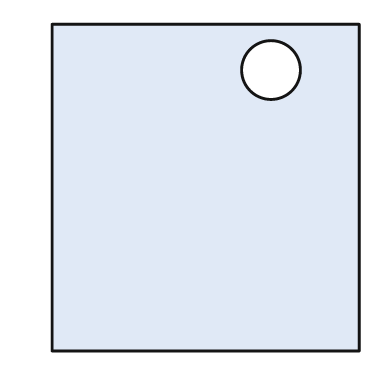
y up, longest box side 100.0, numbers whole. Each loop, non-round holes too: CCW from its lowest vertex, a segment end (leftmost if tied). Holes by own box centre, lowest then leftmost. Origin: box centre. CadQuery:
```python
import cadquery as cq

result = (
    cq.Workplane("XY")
    .moveTo(-47.0, -50.0)
    .lineTo(47.0, -50.0)
    .lineTo(47.0, 50.0)
    .lineTo(-47.0, 50.0)
    .close()
    .moveTo(20.0, 36.0)
    .circle(9.0)
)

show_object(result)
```